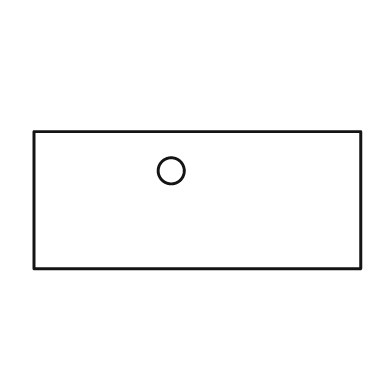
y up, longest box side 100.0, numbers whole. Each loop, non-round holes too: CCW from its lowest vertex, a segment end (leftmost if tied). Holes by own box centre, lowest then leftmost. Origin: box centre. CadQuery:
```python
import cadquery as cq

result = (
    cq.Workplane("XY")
    .moveTo(-50.0, -21.0)
    .lineTo(50.0, -21.0)
    .lineTo(50.0, 21.0)
    .lineTo(-50.0, 21.0)
    .close()
    .moveTo(-8.0, 9.0)
    .circle(4.0)
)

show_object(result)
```